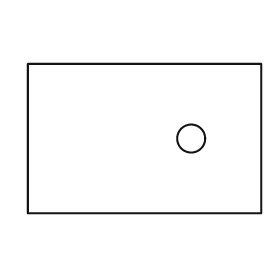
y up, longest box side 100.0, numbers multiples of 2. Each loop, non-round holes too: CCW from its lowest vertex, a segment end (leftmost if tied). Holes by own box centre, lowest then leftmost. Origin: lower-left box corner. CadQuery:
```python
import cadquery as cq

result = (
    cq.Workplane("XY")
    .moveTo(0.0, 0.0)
    .lineTo(100.0, 0.0)
    .lineTo(100.0, 64.0)
    .lineTo(0.0, 64.0)
    .close()
    .moveTo(70.0, 32.0)
    .circle(6.0)
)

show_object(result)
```